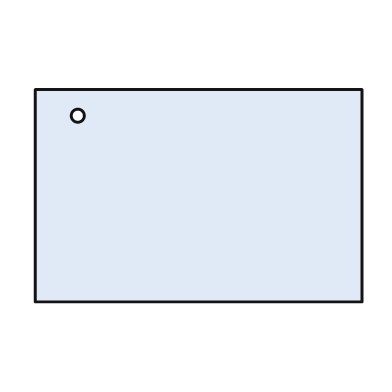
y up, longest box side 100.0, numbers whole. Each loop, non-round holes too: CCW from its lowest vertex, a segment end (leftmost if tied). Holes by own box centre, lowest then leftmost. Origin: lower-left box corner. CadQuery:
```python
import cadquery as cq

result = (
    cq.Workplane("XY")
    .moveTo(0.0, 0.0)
    .lineTo(100.0, 0.0)
    .lineTo(100.0, 65.0)
    .lineTo(0.0, 65.0)
    .close()
    .moveTo(13.0, 57.0)
    .circle(2.0)
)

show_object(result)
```